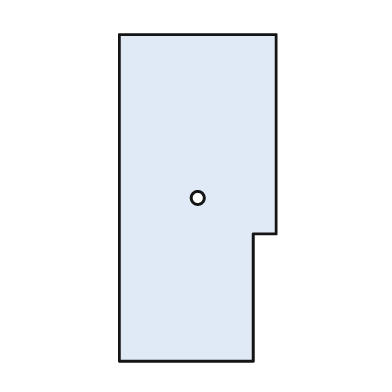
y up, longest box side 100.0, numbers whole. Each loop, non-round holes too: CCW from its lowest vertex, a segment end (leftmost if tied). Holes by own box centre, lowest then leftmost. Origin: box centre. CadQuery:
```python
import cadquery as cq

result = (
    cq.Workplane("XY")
    .moveTo(-24.0, -50.0)
    .lineTo(17.0, -50.0)
    .lineTo(17.0, -11.0)
    .lineTo(24.0, -11.0)
    .lineTo(24.0, 50.0)
    .lineTo(-24.0, 50.0)
    .close()
    .moveTo(0.0, 0.0)
    .circle(2.0)
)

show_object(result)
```